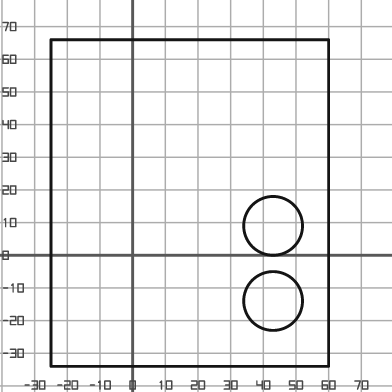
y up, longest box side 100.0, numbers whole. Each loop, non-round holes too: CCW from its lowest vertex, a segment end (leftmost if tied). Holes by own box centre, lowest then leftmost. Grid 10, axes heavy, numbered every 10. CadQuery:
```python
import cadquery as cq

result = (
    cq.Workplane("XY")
    .moveTo(-25.0, -34.0)
    .lineTo(60.0, -34.0)
    .lineTo(60.0, 66.0)
    .lineTo(-25.0, 66.0)
    .close()
    .moveTo(43.0, -14.0)
    .circle(9.0)
    .moveTo(43.0, 9.0)
    .circle(9.0)
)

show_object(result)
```